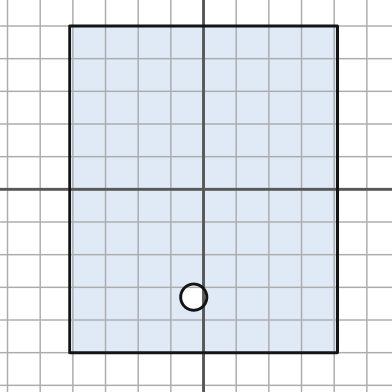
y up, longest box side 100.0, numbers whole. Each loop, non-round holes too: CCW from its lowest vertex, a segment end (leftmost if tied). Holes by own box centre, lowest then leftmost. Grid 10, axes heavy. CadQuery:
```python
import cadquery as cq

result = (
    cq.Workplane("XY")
    .moveTo(-41.0, -50.0)
    .lineTo(41.0, -50.0)
    .lineTo(41.0, 50.0)
    .lineTo(-41.0, 50.0)
    .close()
    .moveTo(-3.0, -33.0)
    .circle(4.0)
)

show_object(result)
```